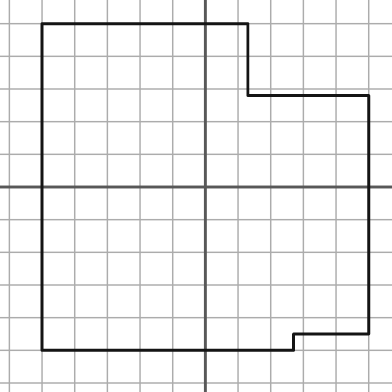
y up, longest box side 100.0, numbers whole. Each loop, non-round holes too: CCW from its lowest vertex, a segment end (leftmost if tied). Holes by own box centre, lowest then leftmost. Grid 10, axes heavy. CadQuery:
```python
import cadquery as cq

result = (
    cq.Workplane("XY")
    .moveTo(-50.0, -50.0)
    .lineTo(27.0, -50.0)
    .lineTo(27.0, -45.0)
    .lineTo(50.0, -45.0)
    .lineTo(50.0, 28.0)
    .lineTo(13.0, 28.0)
    .lineTo(13.0, 50.0)
    .lineTo(-50.0, 50.0)
    .close()
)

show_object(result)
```